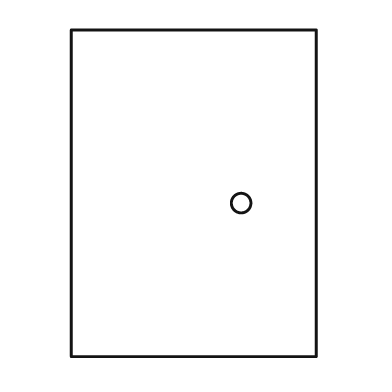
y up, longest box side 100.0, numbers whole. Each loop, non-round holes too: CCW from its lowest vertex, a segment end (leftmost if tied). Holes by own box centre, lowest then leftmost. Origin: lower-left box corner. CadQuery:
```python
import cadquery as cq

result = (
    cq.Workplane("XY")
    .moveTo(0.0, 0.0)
    .lineTo(75.0, 0.0)
    .lineTo(75.0, 100.0)
    .lineTo(0.0, 100.0)
    .close()
    .moveTo(52.0, 47.0)
    .circle(3.0)
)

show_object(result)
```